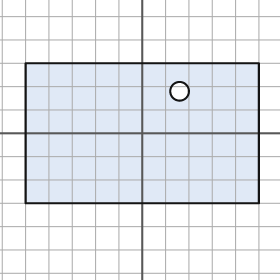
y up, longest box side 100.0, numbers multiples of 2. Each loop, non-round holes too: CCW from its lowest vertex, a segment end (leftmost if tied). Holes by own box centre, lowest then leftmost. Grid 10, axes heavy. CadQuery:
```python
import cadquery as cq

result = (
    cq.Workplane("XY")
    .moveTo(-50.0, -30.0)
    .lineTo(50.0, -30.0)
    .lineTo(50.0, 30.0)
    .lineTo(-50.0, 30.0)
    .close()
    .moveTo(16.0, 18.0)
    .circle(4.0)
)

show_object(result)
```